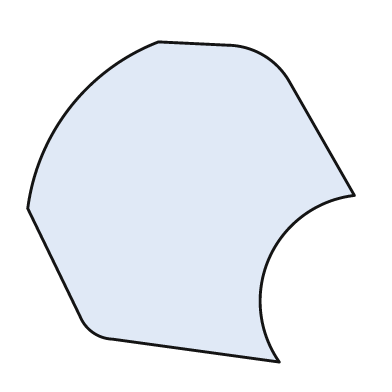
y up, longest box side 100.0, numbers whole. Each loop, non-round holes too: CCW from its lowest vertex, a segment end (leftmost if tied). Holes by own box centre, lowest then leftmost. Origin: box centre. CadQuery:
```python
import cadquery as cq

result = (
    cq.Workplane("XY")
    .moveTo(27.0, -49.0)
    .threePointArc((24.0, -17.0), (50.0, 2.0))
    .lineTo(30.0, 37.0)
    .threePointArc((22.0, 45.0), (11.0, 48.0))
    .lineTo(-10.0, 49.0)
    .threePointArc((-37.0, 29.0), (-50.0, -2.0))
    .lineTo(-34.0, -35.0)
    .threePointArc((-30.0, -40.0), (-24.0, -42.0))
    .close()
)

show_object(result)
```